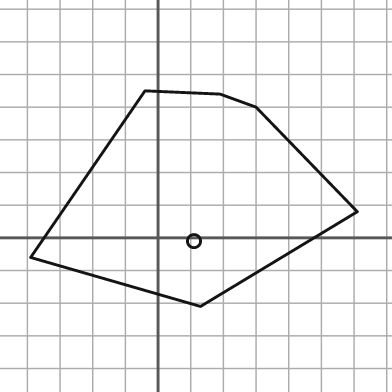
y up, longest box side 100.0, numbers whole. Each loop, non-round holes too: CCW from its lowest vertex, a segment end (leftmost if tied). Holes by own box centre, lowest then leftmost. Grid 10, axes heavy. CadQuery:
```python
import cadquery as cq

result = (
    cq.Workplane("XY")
    .moveTo(13.0, -21.0)
    .lineTo(61.0, 8.0)
    .lineTo(30.0, 40.0)
    .lineTo(19.0, 44.0)
    .lineTo(-4.0, 45.0)
    .lineTo(-39.0, -6.0)
    .close()
    .moveTo(11.0, -1.0)
    .circle(2.0)
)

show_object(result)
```